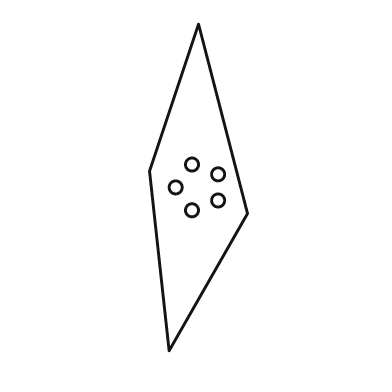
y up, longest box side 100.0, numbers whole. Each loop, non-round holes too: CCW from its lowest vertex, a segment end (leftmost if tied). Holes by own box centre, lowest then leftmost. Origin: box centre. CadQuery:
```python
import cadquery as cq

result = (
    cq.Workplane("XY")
    .moveTo(-9.0, -50.0)
    .lineTo(15.0, -8.0)
    .lineTo(0.0, 50.0)
    .lineTo(-15.0, 5.0)
    .close()
    .moveTo(-2.0, -7.0)
    .circle(2.0)
    .moveTo(6.0, -4.0)
    .circle(2.0)
    .moveTo(-7.0, 0.0)
    .circle(2.0)
    .moveTo(6.0, 4.0)
    .circle(2.0)
    .moveTo(-2.0, 7.0)
    .circle(2.0)
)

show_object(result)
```